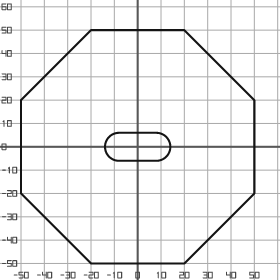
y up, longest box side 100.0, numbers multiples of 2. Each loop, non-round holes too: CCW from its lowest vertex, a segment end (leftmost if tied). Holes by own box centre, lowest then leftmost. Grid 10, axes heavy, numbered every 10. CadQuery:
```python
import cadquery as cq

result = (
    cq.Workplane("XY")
    .moveTo(-20.0, -50.0)
    .lineTo(20.0, -50.0)
    .lineTo(50.0, -20.0)
    .lineTo(50.0, 20.0)
    .lineTo(20.0, 50.0)
    .lineTo(-20.0, 50.0)
    .lineTo(-50.0, 20.0)
    .lineTo(-50.0, -20.0)
    .close()
    .moveTo(-8.0, -6.0)
    .lineTo(8.0, -6.0)
    .threePointArc((14.0, 0.0), (8.0, 6.0))
    .lineTo(-8.0, 6.0)
    .threePointArc((-14.0, 0.0), (-8.0, -6.0))
    .close()
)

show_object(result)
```